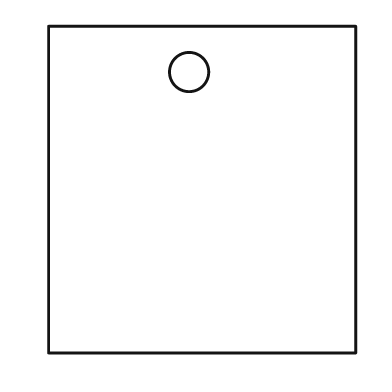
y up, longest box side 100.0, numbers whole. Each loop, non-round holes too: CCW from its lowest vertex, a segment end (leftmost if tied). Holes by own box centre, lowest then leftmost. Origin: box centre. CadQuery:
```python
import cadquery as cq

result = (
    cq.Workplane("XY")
    .moveTo(-47.0, -50.0)
    .lineTo(47.0, -50.0)
    .lineTo(47.0, 50.0)
    .lineTo(-47.0, 50.0)
    .close()
    .moveTo(-4.0, 36.0)
    .circle(6.0)
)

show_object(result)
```